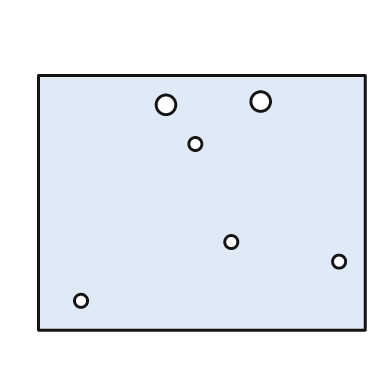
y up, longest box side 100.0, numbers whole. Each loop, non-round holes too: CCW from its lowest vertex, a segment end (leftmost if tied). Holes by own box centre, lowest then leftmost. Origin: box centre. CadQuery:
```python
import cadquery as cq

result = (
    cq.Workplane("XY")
    .moveTo(-50.0, -39.0)
    .lineTo(50.0, -39.0)
    .lineTo(50.0, 39.0)
    .lineTo(-50.0, 39.0)
    .close()
    .moveTo(-37.0, -30.0)
    .circle(2.0)
    .moveTo(42.0, -18.0)
    .circle(2.0)
    .moveTo(9.0, -12.0)
    .circle(2.0)
    .moveTo(-2.0, 18.0)
    .circle(2.0)
    .moveTo(-11.0, 30.0)
    .circle(3.0)
    .moveTo(18.0, 31.0)
    .circle(3.0)
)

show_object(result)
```